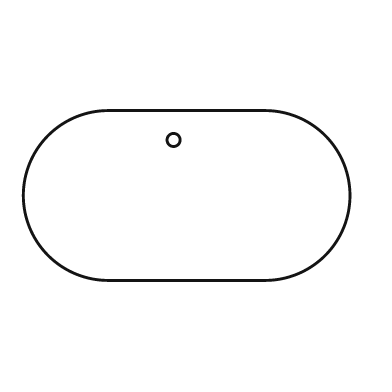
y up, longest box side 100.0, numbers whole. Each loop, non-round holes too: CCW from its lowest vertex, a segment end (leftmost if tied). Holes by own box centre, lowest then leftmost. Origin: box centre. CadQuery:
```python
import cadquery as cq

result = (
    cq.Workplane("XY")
    .moveTo(-24.0, -26.0)
    .lineTo(24.0, -26.0)
    .threePointArc((50.0, 0.0), (24.0, 26.0))
    .lineTo(-24.0, 26.0)
    .threePointArc((-50.0, 0.0), (-24.0, -26.0))
    .close()
    .moveTo(-4.0, 17.0)
    .circle(2.0)
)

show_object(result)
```